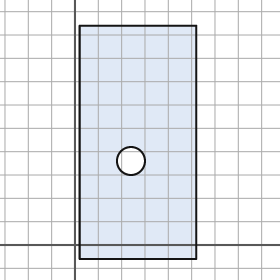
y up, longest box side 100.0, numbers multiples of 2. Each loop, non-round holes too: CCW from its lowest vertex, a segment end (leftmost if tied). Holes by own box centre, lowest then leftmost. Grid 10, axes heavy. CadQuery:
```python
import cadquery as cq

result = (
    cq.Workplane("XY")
    .moveTo(2.0, -6.0)
    .lineTo(52.0, -6.0)
    .lineTo(52.0, 94.0)
    .lineTo(2.0, 94.0)
    .close()
    .moveTo(24.0, 36.0)
    .circle(6.0)
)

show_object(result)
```